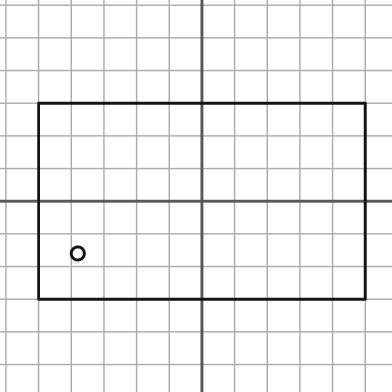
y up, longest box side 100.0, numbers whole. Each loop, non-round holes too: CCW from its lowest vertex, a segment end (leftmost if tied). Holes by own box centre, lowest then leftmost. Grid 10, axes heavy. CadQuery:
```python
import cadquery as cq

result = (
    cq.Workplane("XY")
    .moveTo(-50.0, -30.0)
    .lineTo(50.0, -30.0)
    .lineTo(50.0, 30.0)
    .lineTo(-50.0, 30.0)
    .close()
    .moveTo(-38.0, -16.0)
    .circle(2.0)
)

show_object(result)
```